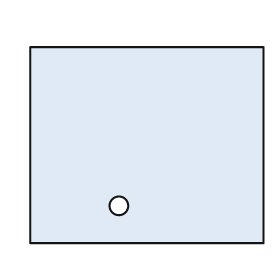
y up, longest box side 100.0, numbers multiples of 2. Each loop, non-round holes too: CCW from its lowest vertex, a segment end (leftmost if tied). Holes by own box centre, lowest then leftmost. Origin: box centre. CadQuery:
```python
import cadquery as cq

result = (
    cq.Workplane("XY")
    .moveTo(-50.0, -42.0)
    .lineTo(50.0, -42.0)
    .lineTo(50.0, 42.0)
    .lineTo(-50.0, 42.0)
    .close()
    .moveTo(-12.0, -26.0)
    .circle(4.0)
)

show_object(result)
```